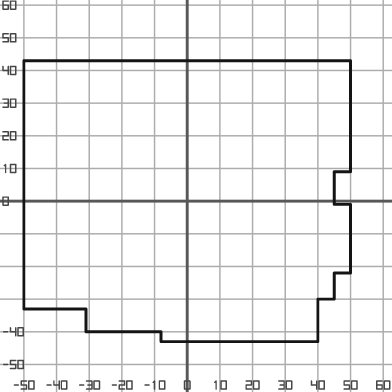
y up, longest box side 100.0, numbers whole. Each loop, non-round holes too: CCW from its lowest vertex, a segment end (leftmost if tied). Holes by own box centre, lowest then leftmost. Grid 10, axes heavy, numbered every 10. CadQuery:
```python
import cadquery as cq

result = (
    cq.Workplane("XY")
    .moveTo(-8.0, -43.0)
    .lineTo(40.0, -43.0)
    .lineTo(40.0, -30.0)
    .lineTo(45.0, -30.0)
    .lineTo(45.0, -22.0)
    .lineTo(50.0, -22.0)
    .lineTo(50.0, -1.0)
    .lineTo(45.0, -1.0)
    .lineTo(45.0, 9.0)
    .lineTo(50.0, 9.0)
    .lineTo(50.0, 43.0)
    .lineTo(-50.0, 43.0)
    .lineTo(-50.0, -33.0)
    .lineTo(-31.0, -33.0)
    .lineTo(-31.0, -40.0)
    .lineTo(-8.0, -40.0)
    .close()
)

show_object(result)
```